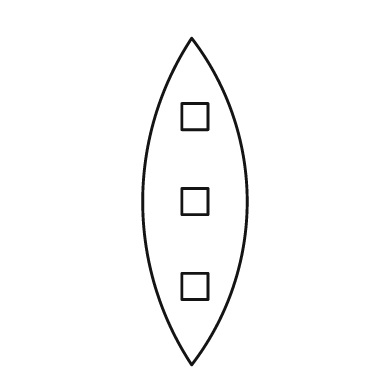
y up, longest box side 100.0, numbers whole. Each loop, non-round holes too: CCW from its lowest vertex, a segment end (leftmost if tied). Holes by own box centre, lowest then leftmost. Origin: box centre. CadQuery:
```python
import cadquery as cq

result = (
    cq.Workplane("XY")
    .moveTo(-1.0, -50.0)
    .threePointArc((16.0, 0.0), (-1.0, 50.0))
    .threePointArc((-16.0, 0.0), (-1.0, -50.0))
    .close()
    .moveTo(-4.0, -30.0)
    .lineTo(4.0, -30.0)
    .lineTo(4.0, -22.0)
    .lineTo(-4.0, -22.0)
    .close()
    .moveTo(-4.0, -4.0)
    .lineTo(4.0, -4.0)
    .lineTo(4.0, 4.0)
    .lineTo(-4.0, 4.0)
    .close()
    .moveTo(-4.0, 22.0)
    .lineTo(4.0, 22.0)
    .lineTo(4.0, 30.0)
    .lineTo(-4.0, 30.0)
    .close()
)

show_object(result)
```